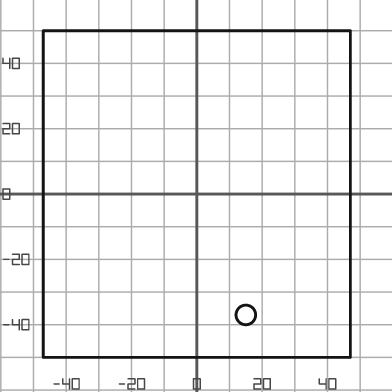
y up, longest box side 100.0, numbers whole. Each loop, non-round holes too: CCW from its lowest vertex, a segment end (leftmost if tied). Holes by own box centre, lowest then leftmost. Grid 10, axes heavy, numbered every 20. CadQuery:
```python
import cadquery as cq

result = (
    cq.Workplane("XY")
    .moveTo(-47.0, -50.0)
    .lineTo(47.0, -50.0)
    .lineTo(47.0, 50.0)
    .lineTo(-47.0, 50.0)
    .close()
    .moveTo(15.0, -37.0)
    .circle(3.0)
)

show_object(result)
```